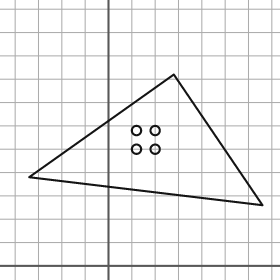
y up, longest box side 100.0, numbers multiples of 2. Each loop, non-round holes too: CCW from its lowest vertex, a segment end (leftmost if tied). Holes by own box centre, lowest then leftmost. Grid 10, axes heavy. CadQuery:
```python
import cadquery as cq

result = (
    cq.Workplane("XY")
    .moveTo(66.0, 26.0)
    .lineTo(28.0, 82.0)
    .lineTo(-34.0, 38.0)
    .close()
    .moveTo(12.0, 50.0)
    .circle(2.0)
    .moveTo(20.0, 50.0)
    .circle(2.0)
    .moveTo(12.0, 58.0)
    .circle(2.0)
    .moveTo(20.0, 58.0)
    .circle(2.0)
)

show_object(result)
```